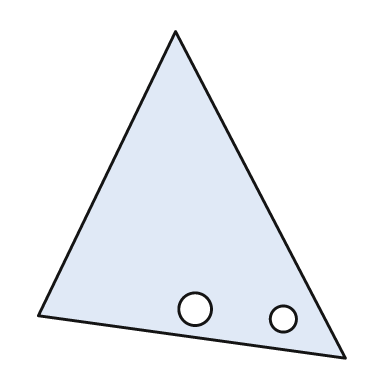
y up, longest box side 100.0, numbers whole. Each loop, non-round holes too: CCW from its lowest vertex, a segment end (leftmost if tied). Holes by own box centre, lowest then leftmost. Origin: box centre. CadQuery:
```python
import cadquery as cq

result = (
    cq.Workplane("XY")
    .moveTo(47.0, -50.0)
    .lineTo(-5.0, 50.0)
    .lineTo(-47.0, -37.0)
    .close()
    .moveTo(28.0, -38.0)
    .circle(4.0)
    .moveTo(1.0, -35.0)
    .circle(5.0)
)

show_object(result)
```